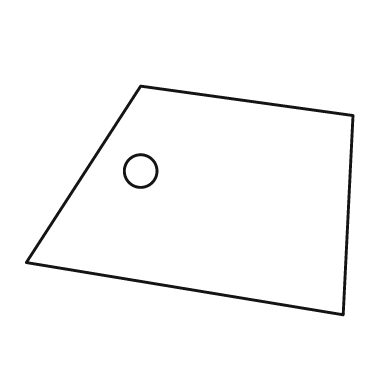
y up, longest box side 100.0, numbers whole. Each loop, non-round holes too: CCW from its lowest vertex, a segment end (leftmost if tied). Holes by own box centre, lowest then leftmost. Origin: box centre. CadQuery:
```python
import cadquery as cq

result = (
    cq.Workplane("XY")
    .moveTo(47.0, -35.0)
    .lineTo(50.0, 26.0)
    .lineTo(-15.0, 35.0)
    .lineTo(-50.0, -19.0)
    .close()
    .moveTo(-15.0, 9.0)
    .circle(5.0)
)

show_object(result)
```